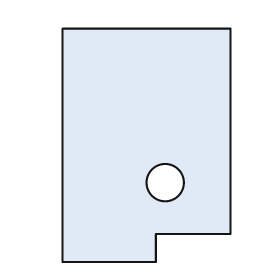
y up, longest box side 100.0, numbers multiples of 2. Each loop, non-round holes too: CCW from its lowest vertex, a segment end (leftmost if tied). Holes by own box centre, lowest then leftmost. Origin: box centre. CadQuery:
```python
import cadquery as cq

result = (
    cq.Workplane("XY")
    .moveTo(-36.0, -50.0)
    .lineTo(4.0, -50.0)
    .lineTo(4.0, -38.0)
    .lineTo(36.0, -38.0)
    .lineTo(36.0, 50.0)
    .lineTo(-36.0, 50.0)
    .close()
    .moveTo(8.0, -16.0)
    .circle(8.0)
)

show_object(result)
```